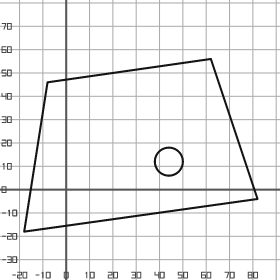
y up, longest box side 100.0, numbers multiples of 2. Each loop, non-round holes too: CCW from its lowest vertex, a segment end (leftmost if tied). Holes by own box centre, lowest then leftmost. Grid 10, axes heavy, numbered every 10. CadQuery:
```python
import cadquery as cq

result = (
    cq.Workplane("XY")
    .moveTo(-18.0, -18.0)
    .lineTo(82.0, -4.0)
    .lineTo(62.0, 56.0)
    .lineTo(-8.0, 46.0)
    .close()
    .moveTo(44.0, 12.0)
    .circle(6.0)
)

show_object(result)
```